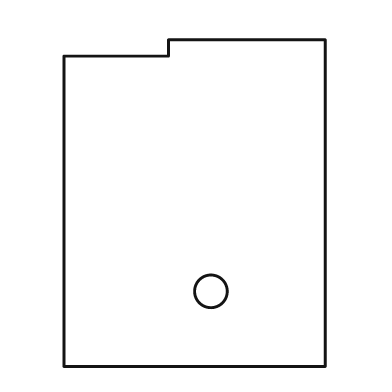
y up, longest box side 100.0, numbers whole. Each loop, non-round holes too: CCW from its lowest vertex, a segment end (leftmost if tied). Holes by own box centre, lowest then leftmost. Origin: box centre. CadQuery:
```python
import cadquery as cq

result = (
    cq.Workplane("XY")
    .moveTo(-40.0, -50.0)
    .lineTo(40.0, -50.0)
    .lineTo(40.0, 50.0)
    .lineTo(-8.0, 50.0)
    .lineTo(-8.0, 45.0)
    .lineTo(-40.0, 45.0)
    .close()
    .moveTo(5.0, -27.0)
    .circle(5.0)
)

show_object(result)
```